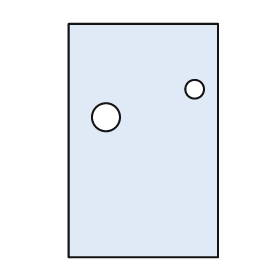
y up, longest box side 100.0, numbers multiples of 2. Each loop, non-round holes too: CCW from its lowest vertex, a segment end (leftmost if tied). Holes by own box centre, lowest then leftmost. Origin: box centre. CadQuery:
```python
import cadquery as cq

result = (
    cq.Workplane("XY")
    .moveTo(-32.0, -50.0)
    .lineTo(32.0, -50.0)
    .lineTo(32.0, 50.0)
    .lineTo(-32.0, 50.0)
    .close()
    .moveTo(-16.0, 10.0)
    .circle(6.0)
    .moveTo(22.0, 22.0)
    .circle(4.0)
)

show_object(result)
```